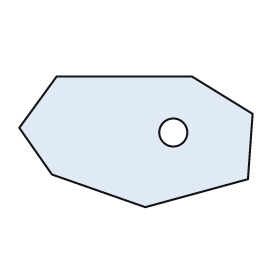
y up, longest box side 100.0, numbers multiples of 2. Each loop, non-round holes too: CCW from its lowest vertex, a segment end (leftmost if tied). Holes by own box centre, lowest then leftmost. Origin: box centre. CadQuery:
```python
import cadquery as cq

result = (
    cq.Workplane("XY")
    .moveTo(4.0, -28.0)
    .lineTo(48.0, -16.0)
    .lineTo(50.0, 12.0)
    .lineTo(24.0, 28.0)
    .lineTo(-34.0, 28.0)
    .lineTo(-50.0, 6.0)
    .lineTo(-36.0, -14.0)
    .close()
    .moveTo(16.0, 4.0)
    .circle(6.0)
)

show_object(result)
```